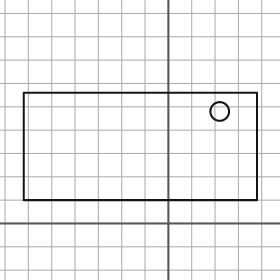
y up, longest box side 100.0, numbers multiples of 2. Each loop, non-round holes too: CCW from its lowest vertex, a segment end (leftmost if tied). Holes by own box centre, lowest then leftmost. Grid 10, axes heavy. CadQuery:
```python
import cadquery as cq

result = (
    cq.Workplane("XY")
    .moveTo(-62.0, 10.0)
    .lineTo(38.0, 10.0)
    .lineTo(38.0, 56.0)
    .lineTo(-62.0, 56.0)
    .close()
    .moveTo(22.0, 48.0)
    .circle(4.0)
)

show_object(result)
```